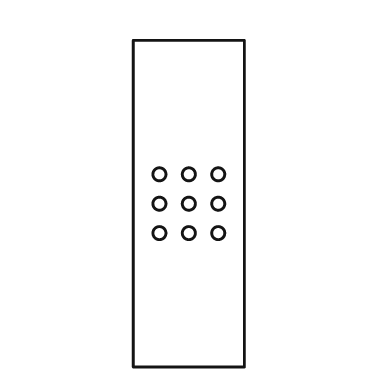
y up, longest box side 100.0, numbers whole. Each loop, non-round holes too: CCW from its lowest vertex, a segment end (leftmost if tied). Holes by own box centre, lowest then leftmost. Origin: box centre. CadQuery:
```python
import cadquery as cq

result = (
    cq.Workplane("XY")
    .moveTo(-17.0, -50.0)
    .lineTo(17.0, -50.0)
    .lineTo(17.0, 50.0)
    .lineTo(-17.0, 50.0)
    .close()
    .moveTo(-9.0, -9.0)
    .circle(2.0)
    .moveTo(0.0, -9.0)
    .circle(2.0)
    .moveTo(9.0, -9.0)
    .circle(2.0)
    .moveTo(-9.0, 0.0)
    .circle(2.0)
    .moveTo(0.0, 0.0)
    .circle(2.0)
    .moveTo(9.0, 0.0)
    .circle(2.0)
    .moveTo(-9.0, 9.0)
    .circle(2.0)
    .moveTo(0.0, 9.0)
    .circle(2.0)
    .moveTo(9.0, 9.0)
    .circle(2.0)
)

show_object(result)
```